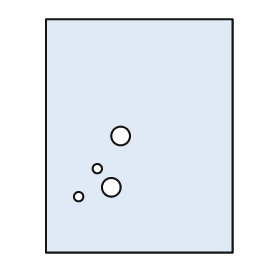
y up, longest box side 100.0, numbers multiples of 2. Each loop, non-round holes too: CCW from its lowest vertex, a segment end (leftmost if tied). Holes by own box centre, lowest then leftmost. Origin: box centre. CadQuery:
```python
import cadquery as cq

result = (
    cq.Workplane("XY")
    .moveTo(-40.0, -50.0)
    .lineTo(40.0, -50.0)
    .lineTo(40.0, 50.0)
    .lineTo(-40.0, 50.0)
    .close()
    .moveTo(-26.0, -26.0)
    .circle(2.0)
    .moveTo(-12.0, -22.0)
    .circle(4.0)
    .moveTo(-18.0, -14.0)
    .circle(2.0)
    .moveTo(-8.0, 0.0)
    .circle(4.0)
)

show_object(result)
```